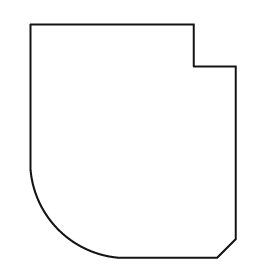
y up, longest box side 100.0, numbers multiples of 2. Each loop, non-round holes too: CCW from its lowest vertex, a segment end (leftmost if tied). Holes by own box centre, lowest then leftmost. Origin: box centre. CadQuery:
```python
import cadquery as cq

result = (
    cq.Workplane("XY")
    .moveTo(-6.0, -50.0)
    .lineTo(36.0, -50.0)
    .lineTo(44.0, -42.0)
    .lineTo(44.0, 32.0)
    .lineTo(26.0, 32.0)
    .lineTo(26.0, 50.0)
    .lineTo(-44.0, 50.0)
    .lineTo(-44.0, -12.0)
    .threePointArc((-32.0, -38.0), (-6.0, -50.0))
    .close()
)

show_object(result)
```